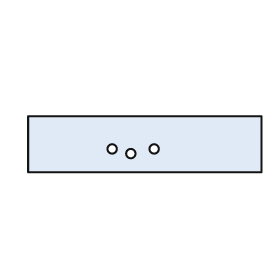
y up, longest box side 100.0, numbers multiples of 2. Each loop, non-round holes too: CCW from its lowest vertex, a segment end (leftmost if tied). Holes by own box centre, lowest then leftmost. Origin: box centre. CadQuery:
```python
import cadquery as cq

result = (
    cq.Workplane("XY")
    .moveTo(-50.0, -12.0)
    .lineTo(50.0, -12.0)
    .lineTo(50.0, 12.0)
    .lineTo(-50.0, 12.0)
    .close()
    .moveTo(-6.0, -4.0)
    .circle(2.0)
    .moveTo(-14.0, -2.0)
    .circle(2.0)
    .moveTo(4.0, -2.0)
    .circle(2.0)
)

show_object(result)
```